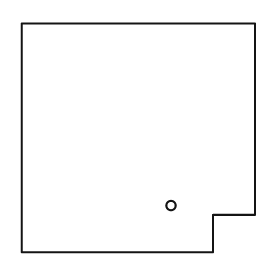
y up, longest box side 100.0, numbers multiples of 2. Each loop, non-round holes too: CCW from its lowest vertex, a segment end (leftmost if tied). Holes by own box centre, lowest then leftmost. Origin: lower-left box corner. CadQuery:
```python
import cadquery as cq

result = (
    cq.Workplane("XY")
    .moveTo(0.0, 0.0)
    .lineTo(82.0, 0.0)
    .lineTo(82.0, 16.0)
    .lineTo(100.0, 16.0)
    .lineTo(100.0, 98.0)
    .lineTo(0.0, 98.0)
    .close()
    .moveTo(64.0, 20.0)
    .circle(2.0)
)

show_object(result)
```